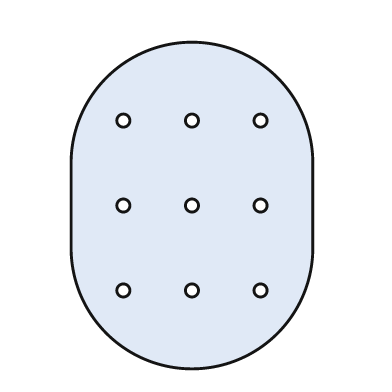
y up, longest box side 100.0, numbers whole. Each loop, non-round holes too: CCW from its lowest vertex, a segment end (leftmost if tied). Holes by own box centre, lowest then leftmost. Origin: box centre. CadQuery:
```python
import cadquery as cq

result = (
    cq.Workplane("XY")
    .moveTo(-37.0, -13.0)
    .threePointArc((0.0, -50.0), (37.0, -13.0))
    .lineTo(37.0, 13.0)
    .threePointArc((0.0, 50.0), (-37.0, 13.0))
    .close()
    .moveTo(-21.0, -26.0)
    .circle(2.0)
    .moveTo(0.0, -26.0)
    .circle(2.0)
    .moveTo(21.0, -26.0)
    .circle(2.0)
    .moveTo(-21.0, 0.0)
    .circle(2.0)
    .moveTo(0.0, 0.0)
    .circle(2.0)
    .moveTo(21.0, 0.0)
    .circle(2.0)
    .moveTo(-21.0, 26.0)
    .circle(2.0)
    .moveTo(0.0, 26.0)
    .circle(2.0)
    .moveTo(21.0, 26.0)
    .circle(2.0)
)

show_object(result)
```